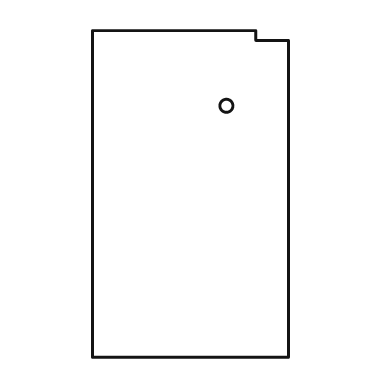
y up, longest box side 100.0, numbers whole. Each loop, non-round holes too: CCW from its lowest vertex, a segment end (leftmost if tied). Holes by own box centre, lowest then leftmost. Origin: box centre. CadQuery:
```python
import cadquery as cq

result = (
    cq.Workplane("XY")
    .moveTo(-30.0, -50.0)
    .lineTo(30.0, -50.0)
    .lineTo(30.0, 47.0)
    .lineTo(20.0, 47.0)
    .lineTo(20.0, 50.0)
    .lineTo(-30.0, 50.0)
    .close()
    .moveTo(11.0, 27.0)
    .circle(2.0)
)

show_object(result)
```